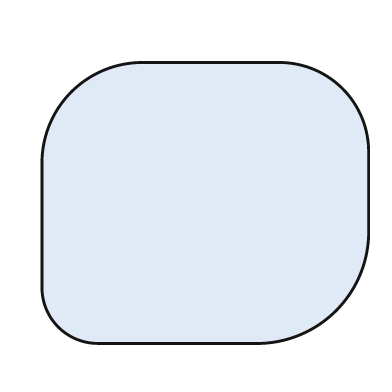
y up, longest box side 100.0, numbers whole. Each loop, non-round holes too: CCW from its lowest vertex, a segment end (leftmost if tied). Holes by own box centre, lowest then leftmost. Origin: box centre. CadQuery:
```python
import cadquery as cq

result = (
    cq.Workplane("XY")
    .moveTo(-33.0, -43.0)
    .lineTo(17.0, -43.0)
    .threePointArc((40.0, -33.0), (50.0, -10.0))
    .lineTo(50.0, 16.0)
    .threePointArc((42.0, 35.0), (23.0, 43.0))
    .lineTo(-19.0, 43.0)
    .threePointArc((-41.0, 34.0), (-50.0, 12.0))
    .lineTo(-50.0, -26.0)
    .threePointArc((-45.0, -38.0), (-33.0, -43.0))
    .close()
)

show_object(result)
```